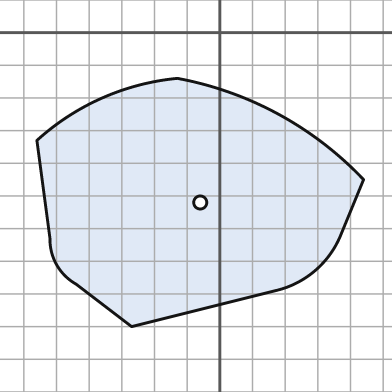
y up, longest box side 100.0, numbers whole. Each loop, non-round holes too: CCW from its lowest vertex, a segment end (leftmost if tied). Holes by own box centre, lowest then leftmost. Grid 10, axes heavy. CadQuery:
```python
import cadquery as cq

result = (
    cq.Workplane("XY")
    .moveTo(-27.0, -90.0)
    .lineTo(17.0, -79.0)
    .threePointArc((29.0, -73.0), (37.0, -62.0))
    .lineTo(44.0, -45.0)
    .threePointArc((18.0, -25.0), (-13.0, -14.0))
    .threePointArc((-36.0, -20.0), (-56.0, -33.0))
    .lineTo(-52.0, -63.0)
    .threePointArc((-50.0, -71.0), (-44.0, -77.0))
    .close()
    .moveTo(-6.0, -52.0)
    .circle(2.0)
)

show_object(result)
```